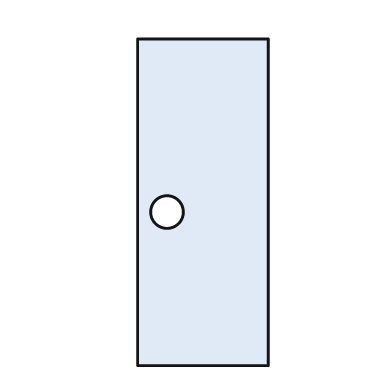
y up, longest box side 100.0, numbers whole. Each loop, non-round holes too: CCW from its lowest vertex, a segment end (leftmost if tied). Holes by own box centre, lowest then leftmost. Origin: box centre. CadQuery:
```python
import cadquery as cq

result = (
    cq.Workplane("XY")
    .moveTo(-20.0, -50.0)
    .lineTo(20.0, -50.0)
    .lineTo(20.0, 50.0)
    .lineTo(-20.0, 50.0)
    .close()
    .moveTo(-11.0, -3.0)
    .circle(5.0)
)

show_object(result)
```